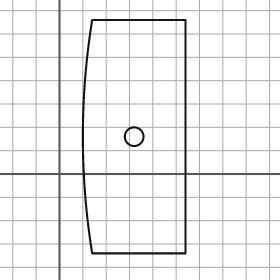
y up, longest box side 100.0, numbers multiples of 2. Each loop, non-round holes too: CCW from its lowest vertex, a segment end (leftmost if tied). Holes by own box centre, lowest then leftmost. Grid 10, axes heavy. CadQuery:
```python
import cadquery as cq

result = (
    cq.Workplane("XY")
    .moveTo(14.0, -34.0)
    .lineTo(54.0, -34.0)
    .lineTo(54.0, 66.0)
    .lineTo(14.0, 66.0)
    .threePointArc((10.0, 16.0), (14.0, -34.0))
    .close()
    .moveTo(32.0, 16.0)
    .circle(4.0)
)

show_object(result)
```